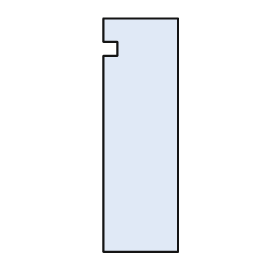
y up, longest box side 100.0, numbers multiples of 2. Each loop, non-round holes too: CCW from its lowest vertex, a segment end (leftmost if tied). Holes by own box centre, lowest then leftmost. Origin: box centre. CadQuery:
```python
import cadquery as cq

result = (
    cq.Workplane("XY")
    .moveTo(-16.0, -50.0)
    .lineTo(16.0, -50.0)
    .lineTo(16.0, 50.0)
    .lineTo(-16.0, 50.0)
    .lineTo(-16.0, 40.0)
    .lineTo(-10.0, 40.0)
    .lineTo(-10.0, 34.0)
    .lineTo(-16.0, 34.0)
    .close()
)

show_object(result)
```